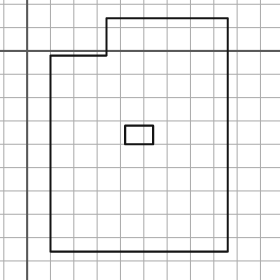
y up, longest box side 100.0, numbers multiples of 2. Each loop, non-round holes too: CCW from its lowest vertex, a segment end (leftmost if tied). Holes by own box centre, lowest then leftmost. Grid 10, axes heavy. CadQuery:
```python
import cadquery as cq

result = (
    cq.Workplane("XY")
    .moveTo(10.0, -86.0)
    .lineTo(86.0, -86.0)
    .lineTo(86.0, 14.0)
    .lineTo(34.0, 14.0)
    .lineTo(34.0, -2.0)
    .lineTo(10.0, -2.0)
    .close()
    .moveTo(42.0, -40.0)
    .lineTo(54.0, -40.0)
    .lineTo(54.0, -32.0)
    .lineTo(42.0, -32.0)
    .close()
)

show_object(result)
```